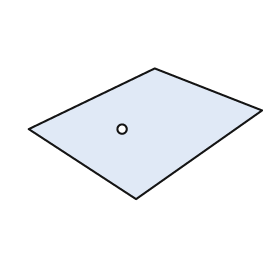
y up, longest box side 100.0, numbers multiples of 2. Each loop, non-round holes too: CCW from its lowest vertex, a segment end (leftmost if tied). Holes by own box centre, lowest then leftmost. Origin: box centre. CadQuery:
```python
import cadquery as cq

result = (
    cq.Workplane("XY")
    .moveTo(-4.0, -28.0)
    .lineTo(50.0, 10.0)
    .lineTo(4.0, 28.0)
    .lineTo(-50.0, 2.0)
    .close()
    .moveTo(-10.0, 2.0)
    .circle(2.0)
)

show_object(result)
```